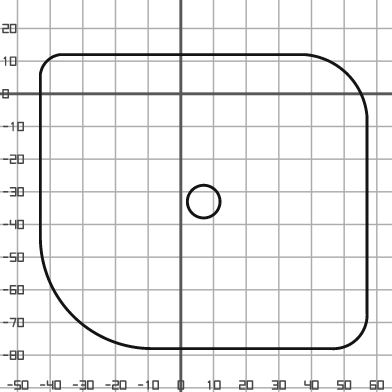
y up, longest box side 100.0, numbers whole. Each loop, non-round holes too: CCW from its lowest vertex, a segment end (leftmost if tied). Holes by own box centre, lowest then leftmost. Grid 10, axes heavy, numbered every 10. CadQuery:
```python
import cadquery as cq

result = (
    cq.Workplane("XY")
    .moveTo(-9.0, -78.0)
    .lineTo(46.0, -78.0)
    .threePointArc((54.0, -75.0), (57.0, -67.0))
    .lineTo(57.0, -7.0)
    .threePointArc((51.0, 6.0), (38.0, 12.0))
    .lineTo(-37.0, 12.0)
    .threePointArc((-41.0, 10.0), (-43.0, 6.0))
    .lineTo(-43.0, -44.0)
    .threePointArc((-33.0, -68.0), (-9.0, -78.0))
    .close()
    .moveTo(7.0, -33.0)
    .circle(5.0)
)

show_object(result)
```